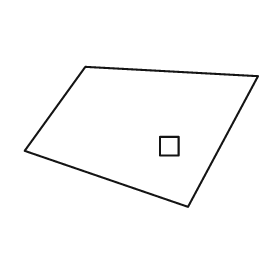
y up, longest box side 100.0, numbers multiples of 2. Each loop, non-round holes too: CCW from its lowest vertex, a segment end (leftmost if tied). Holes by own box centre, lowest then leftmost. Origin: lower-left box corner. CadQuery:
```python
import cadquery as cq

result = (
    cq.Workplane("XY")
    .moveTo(70.0, 0.0)
    .lineTo(100.0, 56.0)
    .lineTo(26.0, 60.0)
    .lineTo(0.0, 24.0)
    .close()
    .moveTo(58.0, 22.0)
    .lineTo(66.0, 22.0)
    .lineTo(66.0, 30.0)
    .lineTo(58.0, 30.0)
    .close()
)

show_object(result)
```